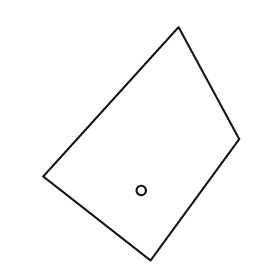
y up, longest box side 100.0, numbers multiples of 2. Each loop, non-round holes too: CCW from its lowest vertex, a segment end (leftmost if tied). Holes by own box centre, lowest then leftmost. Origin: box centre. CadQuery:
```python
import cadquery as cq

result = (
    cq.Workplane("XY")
    .moveTo(4.0, -50.0)
    .lineTo(42.0, 2.0)
    .lineTo(16.0, 50.0)
    .lineTo(-42.0, -14.0)
    .close()
    .moveTo(0.0, -20.0)
    .circle(2.0)
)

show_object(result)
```